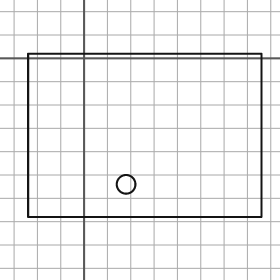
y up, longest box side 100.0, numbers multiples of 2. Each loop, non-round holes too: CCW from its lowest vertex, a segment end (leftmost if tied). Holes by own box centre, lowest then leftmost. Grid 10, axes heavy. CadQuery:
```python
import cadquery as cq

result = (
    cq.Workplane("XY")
    .moveTo(-24.0, -68.0)
    .lineTo(76.0, -68.0)
    .lineTo(76.0, 2.0)
    .lineTo(-24.0, 2.0)
    .close()
    .moveTo(18.0, -54.0)
    .circle(4.0)
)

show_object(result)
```